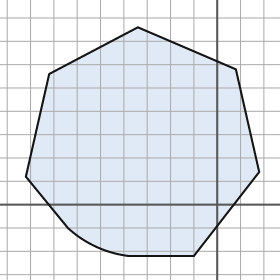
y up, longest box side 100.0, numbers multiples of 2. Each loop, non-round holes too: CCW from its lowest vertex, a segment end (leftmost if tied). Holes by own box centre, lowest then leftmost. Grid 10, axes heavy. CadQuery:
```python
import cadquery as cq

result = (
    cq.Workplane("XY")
    .moveTo(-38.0, -22.0)
    .lineTo(-10.0, -22.0)
    .lineTo(18.0, 14.0)
    .lineTo(8.0, 58.0)
    .lineTo(-34.0, 76.0)
    .lineTo(-72.0, 56.0)
    .lineTo(-82.0, 12.0)
    .lineTo(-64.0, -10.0)
    .threePointArc((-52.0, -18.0), (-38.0, -22.0))
    .close()
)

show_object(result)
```